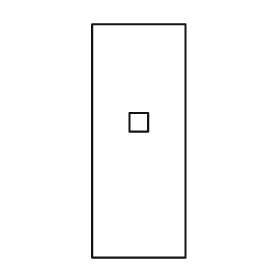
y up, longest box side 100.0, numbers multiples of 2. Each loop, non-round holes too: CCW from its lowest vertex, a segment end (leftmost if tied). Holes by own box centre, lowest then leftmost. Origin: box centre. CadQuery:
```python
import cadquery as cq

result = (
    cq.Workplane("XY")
    .moveTo(-20.0, -50.0)
    .lineTo(20.0, -50.0)
    .lineTo(20.0, 50.0)
    .lineTo(-20.0, 50.0)
    .close()
    .moveTo(-4.0, 4.0)
    .lineTo(4.0, 4.0)
    .lineTo(4.0, 12.0)
    .lineTo(-4.0, 12.0)
    .close()
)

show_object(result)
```